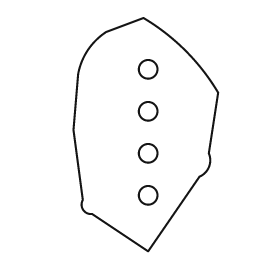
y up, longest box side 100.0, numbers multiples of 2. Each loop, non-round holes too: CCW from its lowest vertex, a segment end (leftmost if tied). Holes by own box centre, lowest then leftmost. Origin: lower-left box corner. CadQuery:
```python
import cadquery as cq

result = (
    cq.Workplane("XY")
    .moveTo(32.0, 0.0)
    .lineTo(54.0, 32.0)
    .threePointArc((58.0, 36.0), (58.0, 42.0))
    .lineTo(62.0, 68.0)
    .threePointArc((48.0, 86.0), (30.0, 100.0))
    .lineTo(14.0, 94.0)
    .threePointArc((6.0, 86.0), (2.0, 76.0))
    .lineTo(0.0, 52.0)
    .lineTo(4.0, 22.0)
    .threePointArc((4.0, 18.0), (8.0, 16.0))
    .close()
    .moveTo(32.0, 24.0)
    .circle(4.0)
    .moveTo(32.0, 42.0)
    .circle(4.0)
    .moveTo(32.0, 60.0)
    .circle(4.0)
    .moveTo(32.0, 78.0)
    .circle(4.0)
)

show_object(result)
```